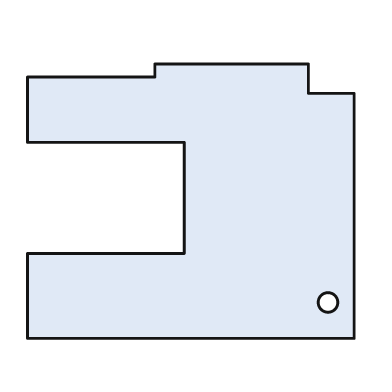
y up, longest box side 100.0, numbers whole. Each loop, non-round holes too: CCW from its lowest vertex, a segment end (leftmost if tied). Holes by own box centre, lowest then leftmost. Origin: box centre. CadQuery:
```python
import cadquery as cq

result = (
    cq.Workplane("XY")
    .moveTo(-50.0, -42.0)
    .lineTo(50.0, -42.0)
    .lineTo(50.0, 33.0)
    .lineTo(36.0, 33.0)
    .lineTo(36.0, 42.0)
    .lineTo(-11.0, 42.0)
    .lineTo(-11.0, 38.0)
    .lineTo(-50.0, 38.0)
    .lineTo(-50.0, 18.0)
    .lineTo(-2.0, 18.0)
    .lineTo(-2.0, -16.0)
    .lineTo(-50.0, -16.0)
    .close()
    .moveTo(42.0, -31.0)
    .circle(3.0)
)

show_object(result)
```